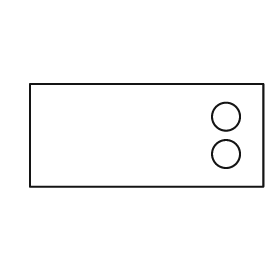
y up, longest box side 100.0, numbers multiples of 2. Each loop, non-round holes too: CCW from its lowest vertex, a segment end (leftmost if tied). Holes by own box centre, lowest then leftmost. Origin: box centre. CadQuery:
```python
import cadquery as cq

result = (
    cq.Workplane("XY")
    .moveTo(-50.0, -22.0)
    .lineTo(50.0, -22.0)
    .lineTo(50.0, 22.0)
    .lineTo(-50.0, 22.0)
    .close()
    .moveTo(34.0, -8.0)
    .circle(6.0)
    .moveTo(34.0, 8.0)
    .circle(6.0)
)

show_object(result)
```